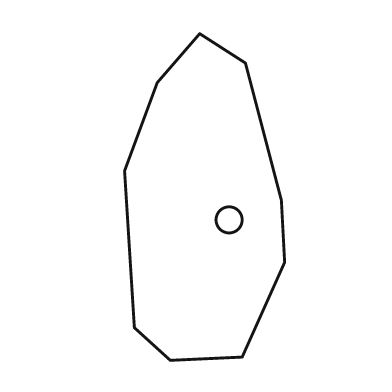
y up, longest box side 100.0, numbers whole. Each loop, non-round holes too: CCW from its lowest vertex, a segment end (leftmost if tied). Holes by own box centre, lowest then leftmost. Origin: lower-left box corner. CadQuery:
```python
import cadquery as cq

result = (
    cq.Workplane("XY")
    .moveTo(14.0, 0.0)
    .lineTo(36.0, 1.0)
    .lineTo(49.0, 30.0)
    .lineTo(48.0, 49.0)
    .lineTo(37.0, 91.0)
    .lineTo(23.0, 100.0)
    .lineTo(10.0, 85.0)
    .lineTo(0.0, 58.0)
    .lineTo(3.0, 10.0)
    .close()
    .moveTo(32.0, 43.0)
    .circle(4.0)
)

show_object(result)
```